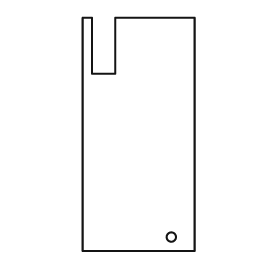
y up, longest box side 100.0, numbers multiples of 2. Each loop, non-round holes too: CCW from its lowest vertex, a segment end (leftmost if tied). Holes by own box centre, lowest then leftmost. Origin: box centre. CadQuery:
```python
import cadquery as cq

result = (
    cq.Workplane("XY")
    .moveTo(-24.0, -50.0)
    .lineTo(24.0, -50.0)
    .lineTo(24.0, 50.0)
    .lineTo(-10.0, 50.0)
    .lineTo(-10.0, 26.0)
    .lineTo(-20.0, 26.0)
    .lineTo(-20.0, 50.0)
    .lineTo(-24.0, 50.0)
    .close()
    .moveTo(14.0, -44.0)
    .circle(2.0)
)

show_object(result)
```